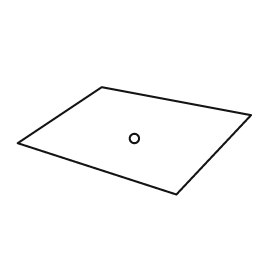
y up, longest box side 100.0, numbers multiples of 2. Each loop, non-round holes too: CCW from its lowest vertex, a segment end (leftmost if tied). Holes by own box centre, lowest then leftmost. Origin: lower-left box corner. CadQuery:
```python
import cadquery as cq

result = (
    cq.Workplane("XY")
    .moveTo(68.0, 0.0)
    .lineTo(100.0, 34.0)
    .lineTo(36.0, 46.0)
    .lineTo(0.0, 22.0)
    .close()
    .moveTo(50.0, 24.0)
    .circle(2.0)
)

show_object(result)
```